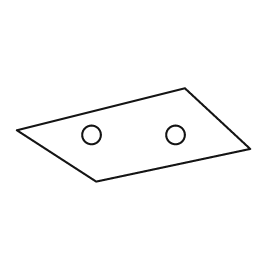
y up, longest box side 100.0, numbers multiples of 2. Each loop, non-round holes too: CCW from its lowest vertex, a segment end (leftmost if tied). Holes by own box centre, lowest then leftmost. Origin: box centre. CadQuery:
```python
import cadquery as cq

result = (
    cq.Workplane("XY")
    .moveTo(-16.0, -20.0)
    .lineTo(50.0, -6.0)
    .lineTo(22.0, 20.0)
    .lineTo(-50.0, 2.0)
    .close()
    .moveTo(-18.0, 0.0)
    .circle(4.0)
    .moveTo(18.0, 0.0)
    .circle(4.0)
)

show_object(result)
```